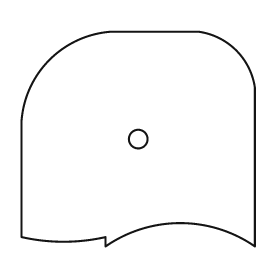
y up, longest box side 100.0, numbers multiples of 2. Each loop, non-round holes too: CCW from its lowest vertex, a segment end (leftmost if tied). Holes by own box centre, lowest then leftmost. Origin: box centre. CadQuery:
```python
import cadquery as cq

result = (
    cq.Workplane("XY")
    .moveTo(-14.0, -46.0)
    .threePointArc((18.0, -36.0), (50.0, -46.0))
    .lineTo(50.0, 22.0)
    .threePointArc((42.0, 38.0), (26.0, 46.0))
    .lineTo(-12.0, 46.0)
    .threePointArc((-38.0, 34.0), (-50.0, 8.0))
    .lineTo(-50.0, -42.0)
    .threePointArc((-32.0, -44.0), (-14.0, -42.0))
    .close()
    .moveTo(0.0, 0.0)
    .circle(4.0)
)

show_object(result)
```